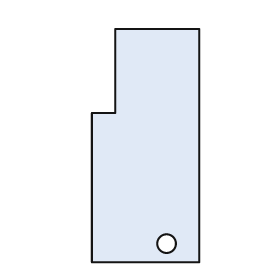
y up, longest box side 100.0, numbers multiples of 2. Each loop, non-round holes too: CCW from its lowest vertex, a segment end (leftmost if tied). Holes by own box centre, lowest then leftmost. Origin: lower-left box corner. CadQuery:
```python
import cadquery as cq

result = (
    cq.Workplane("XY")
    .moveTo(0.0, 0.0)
    .lineTo(46.0, 0.0)
    .lineTo(46.0, 100.0)
    .lineTo(10.0, 100.0)
    .lineTo(10.0, 64.0)
    .lineTo(0.0, 64.0)
    .close()
    .moveTo(32.0, 8.0)
    .circle(4.0)
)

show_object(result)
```